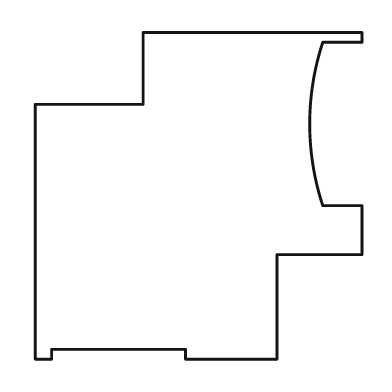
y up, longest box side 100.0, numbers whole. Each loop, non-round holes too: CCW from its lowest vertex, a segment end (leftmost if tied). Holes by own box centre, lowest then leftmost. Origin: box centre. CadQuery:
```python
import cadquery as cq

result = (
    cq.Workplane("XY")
    .moveTo(-50.0, -50.0)
    .lineTo(-45.0, -50.0)
    .lineTo(-45.0, -47.0)
    .lineTo(-4.0, -47.0)
    .lineTo(-4.0, -50.0)
    .lineTo(24.0, -50.0)
    .lineTo(24.0, -18.0)
    .lineTo(50.0, -18.0)
    .lineTo(50.0, -3.0)
    .lineTo(38.0, -3.0)
    .threePointArc((34.0, 22.0), (38.0, 47.0))
    .lineTo(50.0, 47.0)
    .lineTo(50.0, 50.0)
    .lineTo(-17.0, 50.0)
    .lineTo(-17.0, 28.0)
    .lineTo(-50.0, 28.0)
    .close()
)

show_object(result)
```